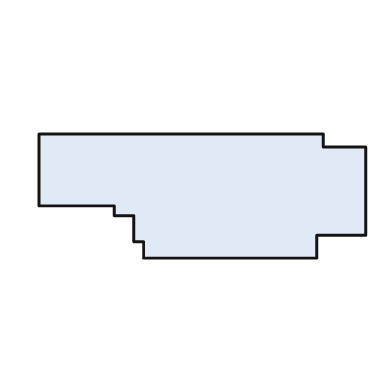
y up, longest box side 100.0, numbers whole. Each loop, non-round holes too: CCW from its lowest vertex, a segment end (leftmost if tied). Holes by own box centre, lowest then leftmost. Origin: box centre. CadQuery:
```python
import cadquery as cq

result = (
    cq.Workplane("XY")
    .moveTo(-18.0, -19.0)
    .lineTo(35.0, -19.0)
    .lineTo(35.0, -12.0)
    .lineTo(50.0, -12.0)
    .lineTo(50.0, 15.0)
    .lineTo(37.0, 15.0)
    .lineTo(37.0, 19.0)
    .lineTo(-50.0, 19.0)
    .lineTo(-50.0, -3.0)
    .lineTo(-27.0, -3.0)
    .lineTo(-27.0, -6.0)
    .lineTo(-21.0, -6.0)
    .lineTo(-21.0, -14.0)
    .lineTo(-18.0, -14.0)
    .close()
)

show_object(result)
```